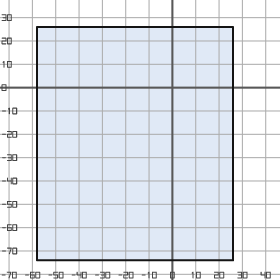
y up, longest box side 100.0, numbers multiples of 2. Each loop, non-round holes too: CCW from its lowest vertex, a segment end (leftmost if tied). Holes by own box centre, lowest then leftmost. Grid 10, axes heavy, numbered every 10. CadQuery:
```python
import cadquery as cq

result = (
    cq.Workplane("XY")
    .moveTo(-58.0, -74.0)
    .lineTo(26.0, -74.0)
    .lineTo(26.0, 26.0)
    .lineTo(-58.0, 26.0)
    .close()
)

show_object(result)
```